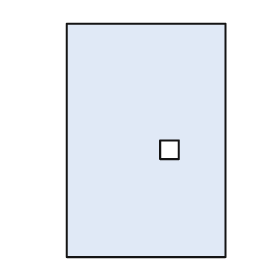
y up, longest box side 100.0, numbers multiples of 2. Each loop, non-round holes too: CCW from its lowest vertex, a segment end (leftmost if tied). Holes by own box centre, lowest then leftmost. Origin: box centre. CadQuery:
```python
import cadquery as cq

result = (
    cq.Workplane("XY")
    .moveTo(-34.0, -50.0)
    .lineTo(34.0, -50.0)
    .lineTo(34.0, 50.0)
    .lineTo(-34.0, 50.0)
    .close()
    .moveTo(6.0, -8.0)
    .lineTo(14.0, -8.0)
    .lineTo(14.0, 0.0)
    .lineTo(6.0, 0.0)
    .close()
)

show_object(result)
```